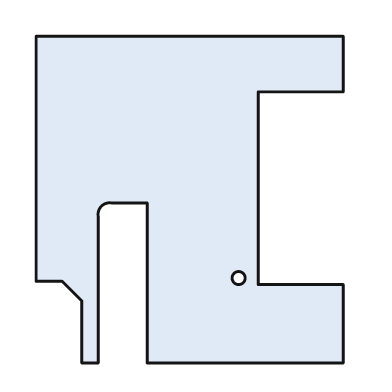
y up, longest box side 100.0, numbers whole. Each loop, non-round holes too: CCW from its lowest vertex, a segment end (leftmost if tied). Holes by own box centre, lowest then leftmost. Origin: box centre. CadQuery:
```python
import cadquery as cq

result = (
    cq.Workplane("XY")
    .moveTo(-33.0, -50.0)
    .lineTo(-28.0, -50.0)
    .lineTo(-28.0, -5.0)
    .threePointArc((-27.0, -2.0), (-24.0, -1.0))
    .lineTo(-13.0, -1.0)
    .lineTo(-13.0, -50.0)
    .lineTo(47.0, -50.0)
    .lineTo(47.0, -26.0)
    .lineTo(21.0, -26.0)
    .lineTo(21.0, 33.0)
    .lineTo(47.0, 33.0)
    .lineTo(47.0, 50.0)
    .lineTo(-47.0, 50.0)
    .lineTo(-47.0, -25.0)
    .lineTo(-39.0, -25.0)
    .lineTo(-33.0, -31.0)
    .close()
    .moveTo(15.0, -24.0)
    .circle(2.0)
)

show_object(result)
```